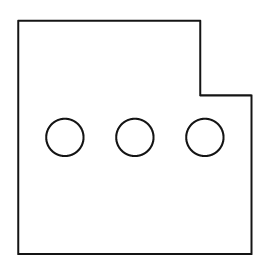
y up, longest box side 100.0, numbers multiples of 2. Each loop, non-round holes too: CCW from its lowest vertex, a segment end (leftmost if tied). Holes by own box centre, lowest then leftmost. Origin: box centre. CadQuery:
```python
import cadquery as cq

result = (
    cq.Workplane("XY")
    .moveTo(-50.0, -50.0)
    .lineTo(50.0, -50.0)
    .lineTo(50.0, 18.0)
    .lineTo(28.0, 18.0)
    .lineTo(28.0, 50.0)
    .lineTo(-50.0, 50.0)
    .close()
    .moveTo(-30.0, 0.0)
    .circle(8.0)
    .moveTo(0.0, 0.0)
    .circle(8.0)
    .moveTo(30.0, 0.0)
    .circle(8.0)
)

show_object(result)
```